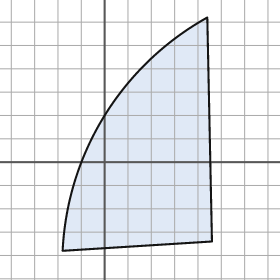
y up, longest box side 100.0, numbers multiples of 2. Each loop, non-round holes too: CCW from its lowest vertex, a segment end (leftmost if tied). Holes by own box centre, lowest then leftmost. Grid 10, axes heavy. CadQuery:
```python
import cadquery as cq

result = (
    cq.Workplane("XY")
    .moveTo(-18.0, -38.0)
    .lineTo(46.0, -34.0)
    .lineTo(44.0, 62.0)
    .threePointArc((0.0, 20.0), (-18.0, -38.0))
    .close()
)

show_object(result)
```